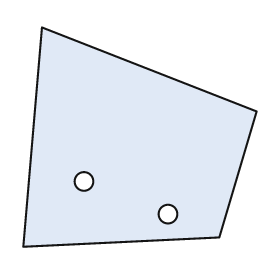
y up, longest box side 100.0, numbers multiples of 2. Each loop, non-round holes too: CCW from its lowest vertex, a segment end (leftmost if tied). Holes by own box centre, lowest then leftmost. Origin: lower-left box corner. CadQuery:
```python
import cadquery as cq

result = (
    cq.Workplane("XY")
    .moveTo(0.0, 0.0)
    .lineTo(84.0, 4.0)
    .lineTo(100.0, 58.0)
    .lineTo(8.0, 94.0)
    .close()
    .moveTo(62.0, 14.0)
    .circle(4.0)
    .moveTo(26.0, 28.0)
    .circle(4.0)
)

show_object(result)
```